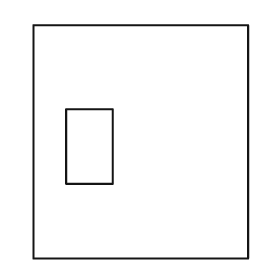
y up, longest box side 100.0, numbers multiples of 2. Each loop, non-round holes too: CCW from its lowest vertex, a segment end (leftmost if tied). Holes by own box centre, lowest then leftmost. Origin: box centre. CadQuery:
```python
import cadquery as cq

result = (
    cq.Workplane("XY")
    .moveTo(-46.0, -50.0)
    .lineTo(46.0, -50.0)
    .lineTo(46.0, 50.0)
    .lineTo(-46.0, 50.0)
    .close()
    .moveTo(-32.0, -18.0)
    .lineTo(-12.0, -18.0)
    .lineTo(-12.0, 14.0)
    .lineTo(-32.0, 14.0)
    .close()
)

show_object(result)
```